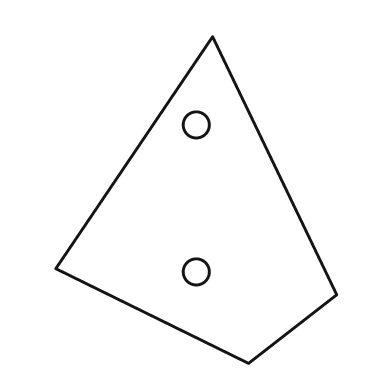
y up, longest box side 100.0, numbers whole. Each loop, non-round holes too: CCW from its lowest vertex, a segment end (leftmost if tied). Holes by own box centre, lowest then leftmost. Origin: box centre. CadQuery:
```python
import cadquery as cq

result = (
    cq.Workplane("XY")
    .moveTo(16.0, -50.0)
    .lineTo(43.0, -29.0)
    .lineTo(5.0, 50.0)
    .lineTo(-43.0, -21.0)
    .close()
    .moveTo(0.0, -22.0)
    .circle(4.0)
    .moveTo(0.0, 23.0)
    .circle(4.0)
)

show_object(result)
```